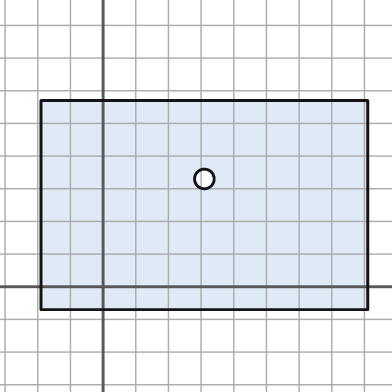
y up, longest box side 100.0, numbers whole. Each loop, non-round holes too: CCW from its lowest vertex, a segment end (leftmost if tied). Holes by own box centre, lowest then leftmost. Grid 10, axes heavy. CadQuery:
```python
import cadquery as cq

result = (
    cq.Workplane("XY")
    .moveTo(-19.0, -7.0)
    .lineTo(81.0, -7.0)
    .lineTo(81.0, 57.0)
    .lineTo(-19.0, 57.0)
    .close()
    .moveTo(31.0, 33.0)
    .circle(3.0)
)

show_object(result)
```